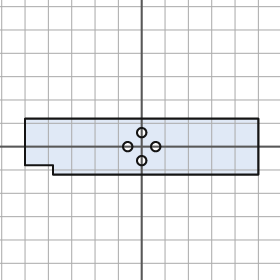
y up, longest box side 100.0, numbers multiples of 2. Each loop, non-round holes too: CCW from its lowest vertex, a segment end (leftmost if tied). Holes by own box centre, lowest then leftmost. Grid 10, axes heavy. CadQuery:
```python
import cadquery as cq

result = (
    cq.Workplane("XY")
    .moveTo(-38.0, -12.0)
    .lineTo(50.0, -12.0)
    .lineTo(50.0, 12.0)
    .lineTo(-50.0, 12.0)
    .lineTo(-50.0, -8.0)
    .lineTo(-38.0, -8.0)
    .close()
    .moveTo(0.0, -6.0)
    .circle(2.0)
    .moveTo(-6.0, 0.0)
    .circle(2.0)
    .moveTo(6.0, 0.0)
    .circle(2.0)
    .moveTo(0.0, 6.0)
    .circle(2.0)
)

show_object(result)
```